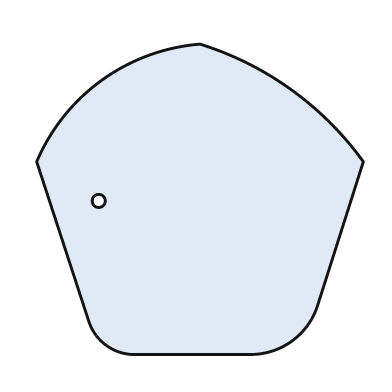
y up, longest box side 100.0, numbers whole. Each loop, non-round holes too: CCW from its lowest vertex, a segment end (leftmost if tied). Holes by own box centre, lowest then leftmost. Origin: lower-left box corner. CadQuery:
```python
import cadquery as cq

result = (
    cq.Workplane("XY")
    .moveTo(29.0, 0.0)
    .lineTo(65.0, 0.0)
    .threePointArc((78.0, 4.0), (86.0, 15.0))
    .lineTo(100.0, 59.0)
    .threePointArc((78.0, 81.0), (50.0, 95.0))
    .threePointArc((20.0, 84.0), (0.0, 59.0))
    .lineTo(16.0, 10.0)
    .threePointArc((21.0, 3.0), (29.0, 0.0))
    .close()
    .moveTo(19.0, 47.0)
    .circle(2.0)
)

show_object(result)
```